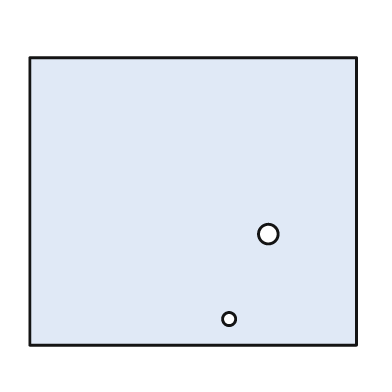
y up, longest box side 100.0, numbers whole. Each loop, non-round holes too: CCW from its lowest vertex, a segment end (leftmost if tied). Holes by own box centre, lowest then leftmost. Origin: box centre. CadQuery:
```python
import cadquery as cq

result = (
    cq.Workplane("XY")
    .moveTo(-50.0, -44.0)
    .lineTo(50.0, -44.0)
    .lineTo(50.0, 44.0)
    .lineTo(-50.0, 44.0)
    .close()
    .moveTo(11.0, -36.0)
    .circle(2.0)
    .moveTo(23.0, -10.0)
    .circle(3.0)
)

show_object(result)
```